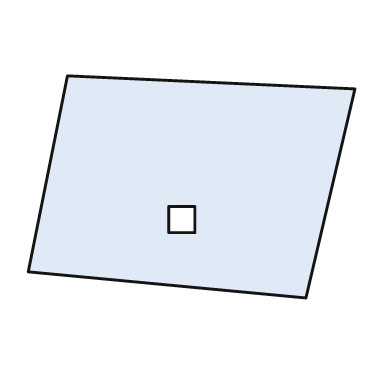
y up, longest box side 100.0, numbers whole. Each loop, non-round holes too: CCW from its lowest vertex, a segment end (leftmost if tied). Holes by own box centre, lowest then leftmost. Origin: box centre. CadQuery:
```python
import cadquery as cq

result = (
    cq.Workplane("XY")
    .moveTo(35.0, -34.0)
    .lineTo(50.0, 30.0)
    .lineTo(-38.0, 34.0)
    .lineTo(-50.0, -26.0)
    .close()
    .moveTo(-7.0, -14.0)
    .lineTo(1.0, -14.0)
    .lineTo(1.0, -6.0)
    .lineTo(-7.0, -6.0)
    .close()
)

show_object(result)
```